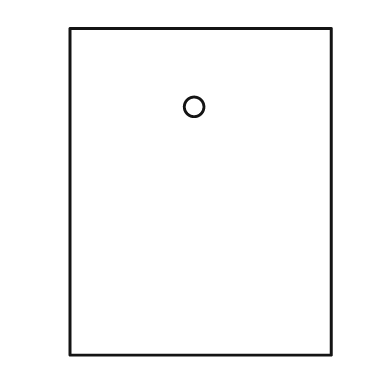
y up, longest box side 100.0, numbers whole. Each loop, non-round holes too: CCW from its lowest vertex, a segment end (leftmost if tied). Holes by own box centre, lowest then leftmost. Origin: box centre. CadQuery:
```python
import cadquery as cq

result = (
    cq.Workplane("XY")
    .moveTo(-40.0, -50.0)
    .lineTo(40.0, -50.0)
    .lineTo(40.0, 50.0)
    .lineTo(-40.0, 50.0)
    .close()
    .moveTo(-2.0, 26.0)
    .circle(3.0)
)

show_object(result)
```